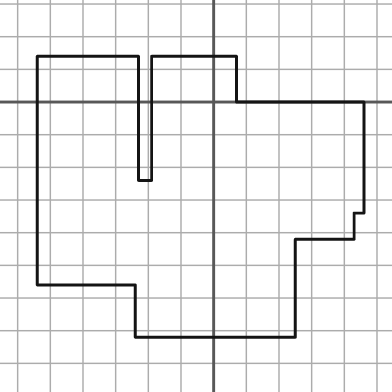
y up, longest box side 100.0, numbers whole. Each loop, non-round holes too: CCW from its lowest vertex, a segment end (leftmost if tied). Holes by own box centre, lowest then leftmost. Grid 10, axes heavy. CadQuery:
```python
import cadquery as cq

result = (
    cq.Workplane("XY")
    .moveTo(-24.0, -72.0)
    .lineTo(25.0, -72.0)
    .lineTo(25.0, -42.0)
    .lineTo(43.0, -42.0)
    .lineTo(43.0, -34.0)
    .lineTo(46.0, -34.0)
    .lineTo(46.0, 0.0)
    .lineTo(7.0, 0.0)
    .lineTo(7.0, 14.0)
    .lineTo(-19.0, 14.0)
    .lineTo(-19.0, -24.0)
    .lineTo(-23.0, -24.0)
    .lineTo(-23.0, 14.0)
    .lineTo(-54.0, 14.0)
    .lineTo(-54.0, -56.0)
    .lineTo(-24.0, -56.0)
    .close()
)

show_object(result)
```